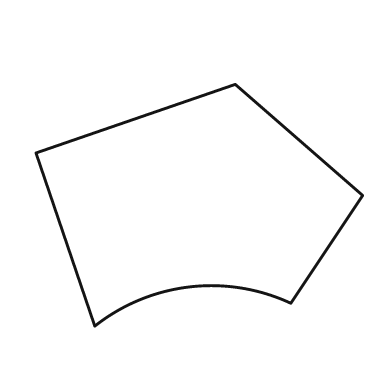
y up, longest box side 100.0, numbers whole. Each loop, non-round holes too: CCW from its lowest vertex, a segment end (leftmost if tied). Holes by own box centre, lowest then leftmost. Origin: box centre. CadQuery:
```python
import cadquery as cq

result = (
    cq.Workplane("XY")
    .moveTo(-32.0, -37.0)
    .threePointArc((-3.0, -25.0), (28.0, -30.0))
    .lineTo(50.0, 3.0)
    .lineTo(11.0, 37.0)
    .lineTo(-50.0, 16.0)
    .close()
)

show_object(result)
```